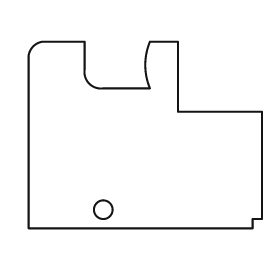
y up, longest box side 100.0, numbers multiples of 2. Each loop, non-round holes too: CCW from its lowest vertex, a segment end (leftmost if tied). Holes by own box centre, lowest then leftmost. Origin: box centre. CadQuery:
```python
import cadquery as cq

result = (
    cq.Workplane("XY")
    .moveTo(-50.0, -40.0)
    .lineTo(46.0, -40.0)
    .lineTo(46.0, -36.0)
    .lineTo(50.0, -36.0)
    .lineTo(50.0, 10.0)
    .lineTo(14.0, 10.0)
    .lineTo(14.0, 40.0)
    .lineTo(2.0, 40.0)
    .threePointArc((0.0, 30.0), (2.0, 20.0))
    .lineTo(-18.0, 20.0)
    .threePointArc((-24.0, 22.0), (-26.0, 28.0))
    .lineTo(-26.0, 40.0)
    .lineTo(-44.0, 40.0)
    .threePointArc((-48.0, 38.0), (-50.0, 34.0))
    .close()
    .moveTo(-18.0, -32.0)
    .circle(4.0)
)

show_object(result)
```